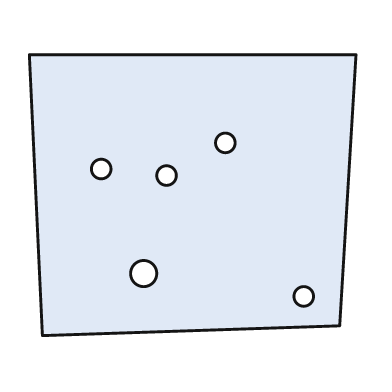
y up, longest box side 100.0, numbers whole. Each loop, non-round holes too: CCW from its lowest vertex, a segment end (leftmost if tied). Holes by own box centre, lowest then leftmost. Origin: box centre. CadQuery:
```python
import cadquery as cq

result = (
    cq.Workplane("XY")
    .moveTo(-46.0, -43.0)
    .lineTo(45.0, -40.0)
    .lineTo(50.0, 43.0)
    .lineTo(-50.0, 43.0)
    .close()
    .moveTo(34.0, -31.0)
    .circle(3.0)
    .moveTo(-15.0, -24.0)
    .circle(4.0)
    .moveTo(-8.0, 6.0)
    .circle(3.0)
    .moveTo(-28.0, 8.0)
    .circle(3.0)
    .moveTo(10.0, 16.0)
    .circle(3.0)
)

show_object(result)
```